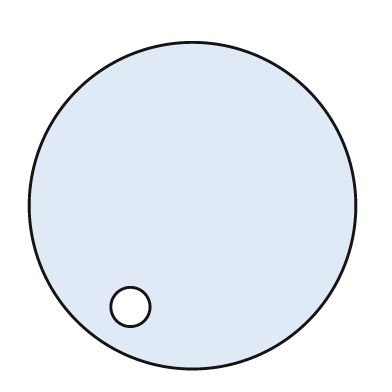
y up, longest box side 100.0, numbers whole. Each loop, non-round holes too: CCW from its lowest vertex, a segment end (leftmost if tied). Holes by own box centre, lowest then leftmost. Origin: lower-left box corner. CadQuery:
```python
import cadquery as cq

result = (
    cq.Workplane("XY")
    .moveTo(50.0, 50.0)
    .circle(50.0)
    .moveTo(31.0, 19.0)
    .circle(6.0)
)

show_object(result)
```